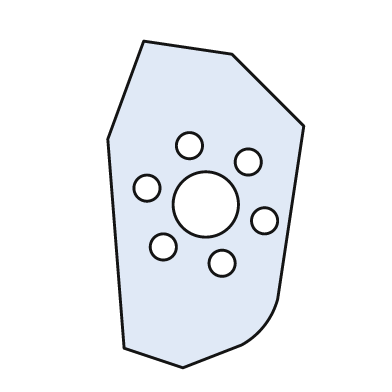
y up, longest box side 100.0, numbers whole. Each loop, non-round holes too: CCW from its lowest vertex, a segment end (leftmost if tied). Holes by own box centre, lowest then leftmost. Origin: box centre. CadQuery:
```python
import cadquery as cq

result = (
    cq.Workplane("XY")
    .moveTo(-7.0, -50.0)
    .lineTo(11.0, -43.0)
    .threePointArc((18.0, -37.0), (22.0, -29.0))
    .lineTo(30.0, 24.0)
    .lineTo(8.0, 46.0)
    .lineTo(-19.0, 50.0)
    .lineTo(-30.0, 20.0)
    .lineTo(-25.0, -44.0)
    .close()
    .moveTo(5.0, -18.0)
    .circle(4.0)
    .moveTo(-13.0, -13.0)
    .circle(4.0)
    .moveTo(18.0, -5.0)
    .circle(4.0)
    .moveTo(0.0, 0.0)
    .circle(10.0)
    .moveTo(-18.0, 5.0)
    .circle(4.0)
    .moveTo(13.0, 13.0)
    .circle(4.0)
    .moveTo(-5.0, 18.0)
    .circle(4.0)
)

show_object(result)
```